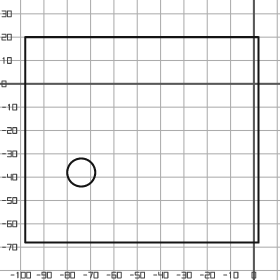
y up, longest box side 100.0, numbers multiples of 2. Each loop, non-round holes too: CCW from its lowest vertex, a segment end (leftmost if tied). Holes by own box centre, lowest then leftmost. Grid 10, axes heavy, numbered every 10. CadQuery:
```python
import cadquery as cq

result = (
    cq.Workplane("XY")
    .moveTo(-98.0, -68.0)
    .lineTo(2.0, -68.0)
    .lineTo(2.0, 20.0)
    .lineTo(-98.0, 20.0)
    .close()
    .moveTo(-74.0, -38.0)
    .circle(6.0)
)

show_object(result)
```